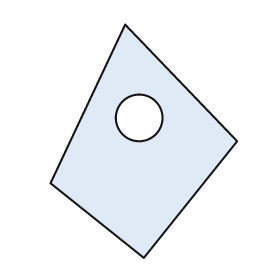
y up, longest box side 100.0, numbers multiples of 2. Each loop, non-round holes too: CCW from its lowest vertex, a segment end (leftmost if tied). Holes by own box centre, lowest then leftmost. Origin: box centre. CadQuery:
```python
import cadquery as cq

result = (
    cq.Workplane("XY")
    .moveTo(0.0, -50.0)
    .lineTo(40.0, 0.0)
    .lineTo(-8.0, 50.0)
    .lineTo(-40.0, -18.0)
    .close()
    .moveTo(-2.0, 10.0)
    .circle(10.0)
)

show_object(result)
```